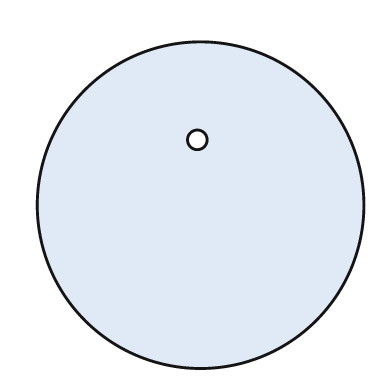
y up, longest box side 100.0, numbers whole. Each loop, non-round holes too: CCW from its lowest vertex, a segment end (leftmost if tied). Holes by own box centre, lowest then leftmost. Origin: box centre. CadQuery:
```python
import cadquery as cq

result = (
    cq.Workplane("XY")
    .moveTo(0.0, 0.0)
    .circle(50.0)
    .moveTo(-1.0, 20.0)
    .circle(3.0)
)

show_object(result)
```